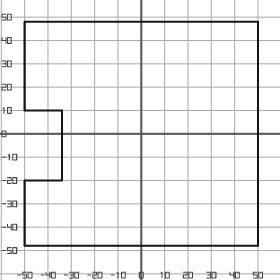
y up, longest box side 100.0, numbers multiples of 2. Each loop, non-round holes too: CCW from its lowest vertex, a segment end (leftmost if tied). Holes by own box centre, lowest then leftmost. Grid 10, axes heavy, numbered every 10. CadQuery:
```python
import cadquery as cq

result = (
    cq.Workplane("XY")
    .moveTo(-50.0, -48.0)
    .lineTo(50.0, -48.0)
    .lineTo(50.0, 48.0)
    .lineTo(-50.0, 48.0)
    .lineTo(-50.0, 10.0)
    .lineTo(-34.0, 10.0)
    .lineTo(-34.0, -20.0)
    .lineTo(-50.0, -20.0)
    .close()
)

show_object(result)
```